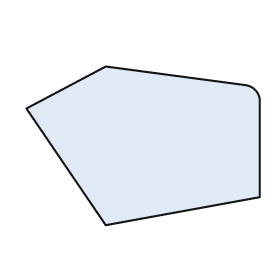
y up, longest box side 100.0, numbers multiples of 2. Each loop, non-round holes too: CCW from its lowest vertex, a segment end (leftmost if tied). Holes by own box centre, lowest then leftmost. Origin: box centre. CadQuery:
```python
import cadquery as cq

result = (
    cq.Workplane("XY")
    .moveTo(-16.0, -34.0)
    .lineTo(50.0, -22.0)
    .lineTo(50.0, 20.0)
    .threePointArc((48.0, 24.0), (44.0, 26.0))
    .lineTo(-16.0, 34.0)
    .lineTo(-50.0, 16.0)
    .close()
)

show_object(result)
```